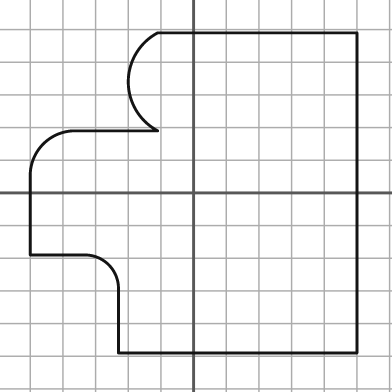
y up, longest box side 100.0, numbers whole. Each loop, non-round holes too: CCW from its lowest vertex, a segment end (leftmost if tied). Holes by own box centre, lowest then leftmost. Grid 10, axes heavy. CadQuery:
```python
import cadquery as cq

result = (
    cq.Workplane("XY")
    .moveTo(-23.0, -49.0)
    .lineTo(50.0, -49.0)
    .lineTo(50.0, 49.0)
    .lineTo(-11.0, 49.0)
    .threePointArc((-20.0, 34.0), (-11.0, 19.0))
    .lineTo(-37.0, 19.0)
    .threePointArc((-46.0, 15.0), (-50.0, 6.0))
    .lineTo(-50.0, -19.0)
    .lineTo(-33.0, -19.0)
    .threePointArc((-26.0, -22.0), (-23.0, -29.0))
    .close()
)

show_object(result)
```